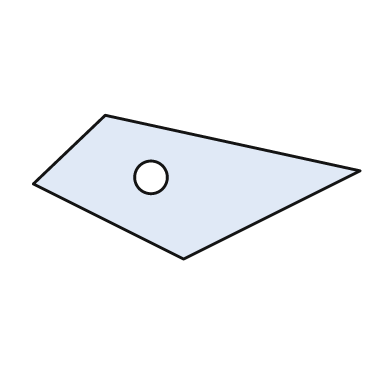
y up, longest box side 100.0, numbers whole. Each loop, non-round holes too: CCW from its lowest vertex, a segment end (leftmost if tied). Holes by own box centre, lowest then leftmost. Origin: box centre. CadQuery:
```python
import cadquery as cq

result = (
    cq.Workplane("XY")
    .moveTo(-4.0, -22.0)
    .lineTo(50.0, 5.0)
    .lineTo(-28.0, 22.0)
    .lineTo(-50.0, 1.0)
    .close()
    .moveTo(-14.0, 3.0)
    .circle(5.0)
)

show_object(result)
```